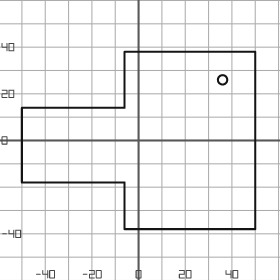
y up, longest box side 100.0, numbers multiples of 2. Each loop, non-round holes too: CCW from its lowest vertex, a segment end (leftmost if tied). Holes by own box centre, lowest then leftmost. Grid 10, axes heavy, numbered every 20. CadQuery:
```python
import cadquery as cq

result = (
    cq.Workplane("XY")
    .moveTo(-6.0, -38.0)
    .lineTo(50.0, -38.0)
    .lineTo(50.0, 38.0)
    .lineTo(-6.0, 38.0)
    .lineTo(-6.0, 14.0)
    .lineTo(-50.0, 14.0)
    .lineTo(-50.0, -18.0)
    .lineTo(-6.0, -18.0)
    .close()
    .moveTo(36.0, 26.0)
    .circle(2.0)
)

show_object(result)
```